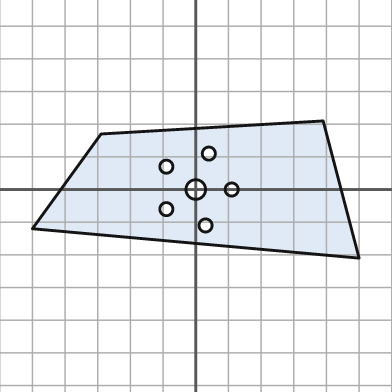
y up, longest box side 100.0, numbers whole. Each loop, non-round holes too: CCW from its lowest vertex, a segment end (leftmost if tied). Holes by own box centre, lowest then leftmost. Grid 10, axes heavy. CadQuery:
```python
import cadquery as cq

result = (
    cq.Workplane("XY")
    .moveTo(50.0, -21.0)
    .lineTo(39.0, 21.0)
    .lineTo(-29.0, 17.0)
    .lineTo(-50.0, -12.0)
    .close()
    .moveTo(3.0, -11.0)
    .circle(2.0)
    .moveTo(-9.0, -6.0)
    .circle(2.0)
    .moveTo(0.0, 0.0)
    .circle(3.0)
    .moveTo(11.0, 0.0)
    .circle(2.0)
    .moveTo(-9.0, 7.0)
    .circle(2.0)
    .moveTo(4.0, 11.0)
    .circle(2.0)
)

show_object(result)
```